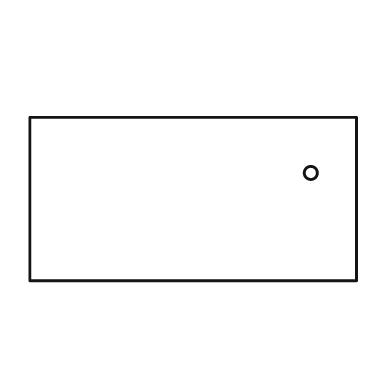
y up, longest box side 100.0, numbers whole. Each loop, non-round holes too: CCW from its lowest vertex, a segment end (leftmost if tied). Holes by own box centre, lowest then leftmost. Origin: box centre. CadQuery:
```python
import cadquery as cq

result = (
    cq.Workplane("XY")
    .moveTo(-50.0, -25.0)
    .lineTo(50.0, -25.0)
    .lineTo(50.0, 25.0)
    .lineTo(-50.0, 25.0)
    .close()
    .moveTo(36.0, 8.0)
    .circle(2.0)
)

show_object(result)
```